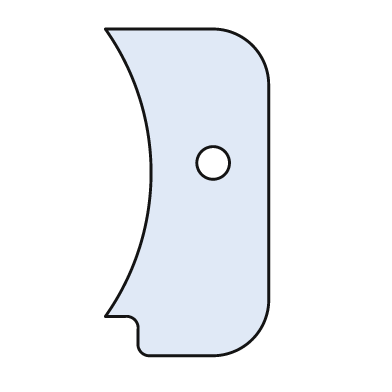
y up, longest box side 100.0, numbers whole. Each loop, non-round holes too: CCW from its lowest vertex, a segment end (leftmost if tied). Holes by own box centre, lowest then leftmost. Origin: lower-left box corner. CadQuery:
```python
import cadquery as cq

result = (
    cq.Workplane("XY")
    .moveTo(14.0, 0.0)
    .lineTo(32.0, 0.0)
    .threePointArc((45.0, 5.0), (50.0, 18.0))
    .lineTo(50.0, 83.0)
    .threePointArc((45.0, 95.0), (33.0, 100.0))
    .lineTo(0.0, 100.0)
    .threePointArc((14.0, 56.0), (0.0, 12.0))
    .lineTo(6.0, 12.0)
    .threePointArc((9.0, 11.0), (10.0, 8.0))
    .lineTo(10.0, 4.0)
    .threePointArc((11.0, 1.0), (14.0, 0.0))
    .close()
    .moveTo(33.0, 59.0)
    .circle(5.0)
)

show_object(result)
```